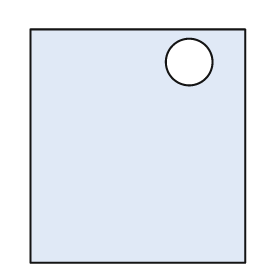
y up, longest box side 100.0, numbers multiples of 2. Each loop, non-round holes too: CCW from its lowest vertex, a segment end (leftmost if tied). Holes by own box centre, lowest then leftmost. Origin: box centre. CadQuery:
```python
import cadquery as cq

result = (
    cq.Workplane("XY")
    .moveTo(-46.0, -50.0)
    .lineTo(46.0, -50.0)
    .lineTo(46.0, 50.0)
    .lineTo(-46.0, 50.0)
    .close()
    .moveTo(22.0, 36.0)
    .circle(10.0)
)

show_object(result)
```